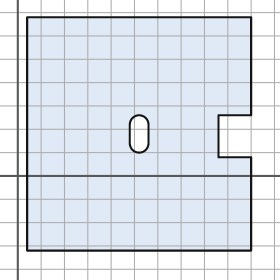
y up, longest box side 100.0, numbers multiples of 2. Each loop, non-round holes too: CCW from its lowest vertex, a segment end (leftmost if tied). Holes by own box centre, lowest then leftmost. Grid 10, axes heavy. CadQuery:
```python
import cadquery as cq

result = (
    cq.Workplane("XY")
    .moveTo(4.0, -32.0)
    .lineTo(100.0, -32.0)
    .lineTo(100.0, 8.0)
    .lineTo(86.0, 8.0)
    .lineTo(86.0, 26.0)
    .lineTo(100.0, 26.0)
    .lineTo(100.0, 68.0)
    .lineTo(4.0, 68.0)
    .close()
    .moveTo(48.0, 14.0)
    .threePointArc((52.0, 10.0), (56.0, 14.0))
    .lineTo(56.0, 22.0)
    .threePointArc((52.0, 26.0), (48.0, 22.0))
    .close()
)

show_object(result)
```